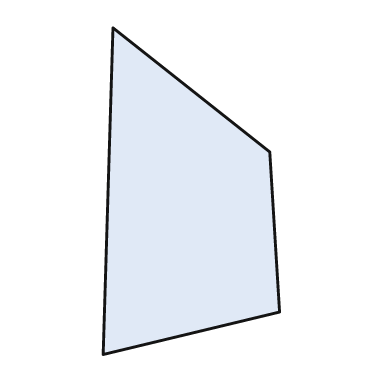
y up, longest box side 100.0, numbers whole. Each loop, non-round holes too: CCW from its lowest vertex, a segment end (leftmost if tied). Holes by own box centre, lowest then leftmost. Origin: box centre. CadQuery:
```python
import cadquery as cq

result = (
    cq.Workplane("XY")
    .moveTo(-27.0, -50.0)
    .lineTo(27.0, -37.0)
    .lineTo(24.0, 12.0)
    .lineTo(-24.0, 50.0)
    .close()
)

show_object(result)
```